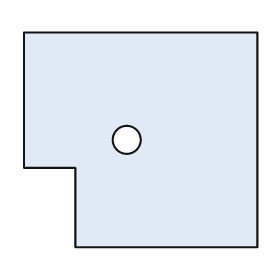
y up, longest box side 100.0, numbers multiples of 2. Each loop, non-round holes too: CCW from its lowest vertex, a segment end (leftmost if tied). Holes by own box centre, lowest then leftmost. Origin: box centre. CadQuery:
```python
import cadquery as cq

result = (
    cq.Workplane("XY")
    .moveTo(-28.0, -46.0)
    .lineTo(50.0, -46.0)
    .lineTo(50.0, 46.0)
    .lineTo(-50.0, 46.0)
    .lineTo(-50.0, -12.0)
    .lineTo(-28.0, -12.0)
    .close()
    .moveTo(-6.0, 0.0)
    .circle(6.0)
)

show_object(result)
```